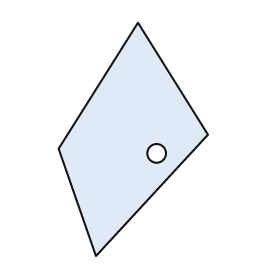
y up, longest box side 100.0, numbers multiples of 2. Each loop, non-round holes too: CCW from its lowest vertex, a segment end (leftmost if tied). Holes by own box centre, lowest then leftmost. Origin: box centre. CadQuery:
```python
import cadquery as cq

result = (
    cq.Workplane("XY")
    .moveTo(-16.0, -50.0)
    .lineTo(32.0, 2.0)
    .lineTo(2.0, 50.0)
    .lineTo(-32.0, -4.0)
    .close()
    .moveTo(10.0, -6.0)
    .circle(4.0)
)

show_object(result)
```